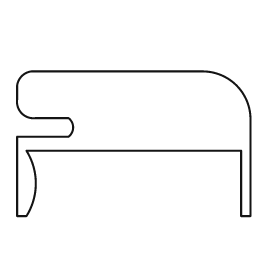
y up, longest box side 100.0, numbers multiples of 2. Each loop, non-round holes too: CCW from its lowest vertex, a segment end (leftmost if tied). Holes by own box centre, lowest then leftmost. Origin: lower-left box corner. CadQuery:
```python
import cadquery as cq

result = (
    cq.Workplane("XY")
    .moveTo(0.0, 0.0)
    .lineTo(4.0, 0.0)
    .threePointArc((8.0, 14.0), (4.0, 28.0))
    .lineTo(96.0, 28.0)
    .lineTo(96.0, 0.0)
    .lineTo(100.0, 0.0)
    .lineTo(100.0, 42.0)
    .threePointArc((94.0, 56.0), (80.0, 62.0))
    .lineTo(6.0, 62.0)
    .threePointArc((2.0, 60.0), (0.0, 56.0))
    .lineTo(0.0, 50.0)
    .threePointArc((2.0, 44.0), (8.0, 42.0))
    .lineTo(22.0, 42.0)
    .threePointArc((24.0, 38.0), (22.0, 34.0))
    .lineTo(0.0, 34.0)
    .close()
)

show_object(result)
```